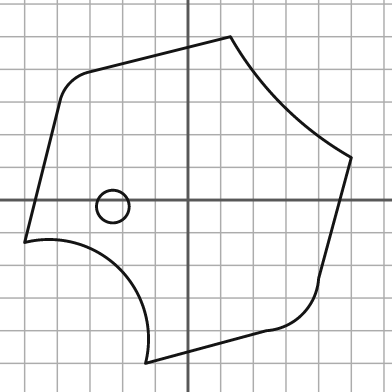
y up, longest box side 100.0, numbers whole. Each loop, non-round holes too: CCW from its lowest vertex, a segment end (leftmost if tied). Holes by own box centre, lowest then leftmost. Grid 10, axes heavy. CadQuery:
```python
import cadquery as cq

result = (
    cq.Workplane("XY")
    .moveTo(-13.0, -50.0)
    .lineTo(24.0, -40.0)
    .threePointArc((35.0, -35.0), (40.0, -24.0))
    .lineTo(50.0, 13.0)
    .threePointArc((29.0, 29.0), (13.0, 50.0))
    .lineTo(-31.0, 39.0)
    .threePointArc((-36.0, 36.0), (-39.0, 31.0))
    .lineTo(-50.0, -13.0)
    .threePointArc((-21.0, -21.0), (-13.0, -50.0))
    .close()
    .moveTo(-23.0, -2.0)
    .circle(5.0)
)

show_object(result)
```